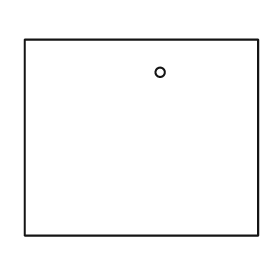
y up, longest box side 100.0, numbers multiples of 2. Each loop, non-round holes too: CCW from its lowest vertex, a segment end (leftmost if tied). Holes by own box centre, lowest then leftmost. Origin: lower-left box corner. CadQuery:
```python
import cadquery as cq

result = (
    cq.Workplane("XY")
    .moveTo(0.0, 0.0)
    .lineTo(100.0, 0.0)
    .lineTo(100.0, 84.0)
    .lineTo(0.0, 84.0)
    .close()
    .moveTo(58.0, 70.0)
    .circle(2.0)
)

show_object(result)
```